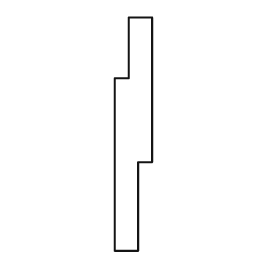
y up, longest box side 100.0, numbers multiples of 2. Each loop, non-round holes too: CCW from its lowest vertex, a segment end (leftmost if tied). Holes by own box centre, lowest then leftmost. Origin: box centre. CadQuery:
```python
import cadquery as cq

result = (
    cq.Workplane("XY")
    .moveTo(-8.0, -50.0)
    .lineTo(2.0, -50.0)
    .lineTo(2.0, -12.0)
    .lineTo(8.0, -12.0)
    .lineTo(8.0, 50.0)
    .lineTo(-2.0, 50.0)
    .lineTo(-2.0, 24.0)
    .lineTo(-8.0, 24.0)
    .close()
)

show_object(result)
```